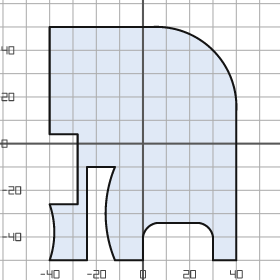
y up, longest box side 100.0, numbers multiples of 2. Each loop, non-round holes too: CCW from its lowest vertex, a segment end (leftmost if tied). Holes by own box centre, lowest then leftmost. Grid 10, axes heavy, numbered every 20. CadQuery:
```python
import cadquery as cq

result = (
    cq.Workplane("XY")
    .moveTo(-40.0, -50.0)
    .lineTo(-24.0, -50.0)
    .lineTo(-24.0, -10.0)
    .lineTo(-12.0, -10.0)
    .threePointArc((-16.0, -30.0), (-12.0, -50.0))
    .lineTo(0.0, -50.0)
    .lineTo(0.0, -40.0)
    .threePointArc((2.0, -36.0), (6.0, -34.0))
    .lineTo(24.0, -34.0)
    .threePointArc((28.0, -36.0), (30.0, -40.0))
    .lineTo(30.0, -50.0)
    .lineTo(40.0, -50.0)
    .lineTo(40.0, 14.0)
    .threePointArc((30.0, 40.0), (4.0, 50.0))
    .lineTo(-40.0, 50.0)
    .lineTo(-40.0, 4.0)
    .lineTo(-28.0, 4.0)
    .lineTo(-28.0, -26.0)
    .lineTo(-40.0, -26.0)
    .threePointArc((-38.0, -38.0), (-40.0, -50.0))
    .close()
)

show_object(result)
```